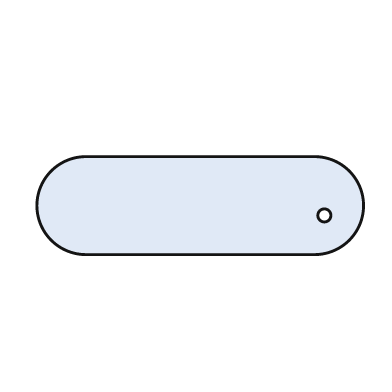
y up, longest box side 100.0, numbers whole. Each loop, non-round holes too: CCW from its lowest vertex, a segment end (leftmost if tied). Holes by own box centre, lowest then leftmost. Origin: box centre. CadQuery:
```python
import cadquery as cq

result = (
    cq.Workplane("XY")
    .moveTo(-35.0, -15.0)
    .lineTo(35.0, -15.0)
    .threePointArc((50.0, 0.0), (35.0, 15.0))
    .lineTo(-35.0, 15.0)
    .threePointArc((-50.0, 0.0), (-35.0, -15.0))
    .close()
    .moveTo(38.0, -3.0)
    .circle(2.0)
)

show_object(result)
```